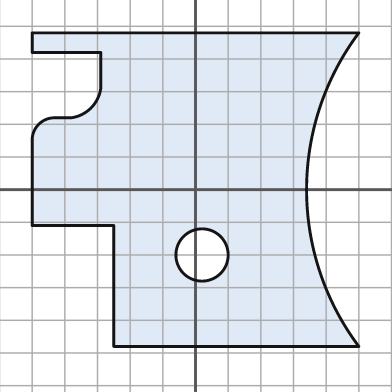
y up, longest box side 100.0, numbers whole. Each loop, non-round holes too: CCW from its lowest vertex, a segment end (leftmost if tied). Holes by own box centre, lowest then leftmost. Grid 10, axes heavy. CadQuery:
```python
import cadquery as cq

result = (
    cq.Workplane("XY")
    .moveTo(-25.0, -48.0)
    .lineTo(50.0, -48.0)
    .threePointArc((34.0, 0.0), (50.0, 48.0))
    .lineTo(-50.0, 48.0)
    .lineTo(-50.0, 42.0)
    .lineTo(-29.0, 42.0)
    .lineTo(-29.0, 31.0)
    .threePointArc((-32.0, 25.0), (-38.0, 22.0))
    .lineTo(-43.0, 22.0)
    .threePointArc((-48.0, 20.0), (-50.0, 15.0))
    .lineTo(-50.0, -11.0)
    .lineTo(-25.0, -11.0)
    .close()
    .moveTo(2.0, -20.0)
    .circle(8.0)
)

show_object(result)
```